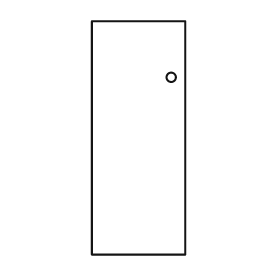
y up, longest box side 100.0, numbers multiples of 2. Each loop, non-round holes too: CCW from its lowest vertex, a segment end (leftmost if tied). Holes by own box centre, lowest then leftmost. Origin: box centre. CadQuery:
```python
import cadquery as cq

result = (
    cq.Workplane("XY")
    .moveTo(-20.0, -50.0)
    .lineTo(20.0, -50.0)
    .lineTo(20.0, 50.0)
    .lineTo(-20.0, 50.0)
    .close()
    .moveTo(14.0, 26.0)
    .circle(2.0)
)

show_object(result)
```